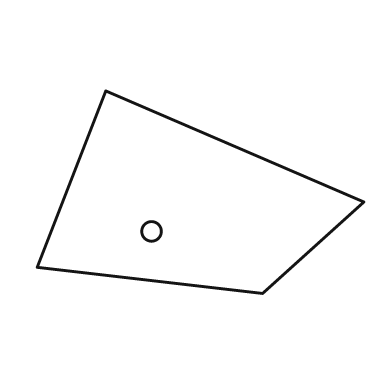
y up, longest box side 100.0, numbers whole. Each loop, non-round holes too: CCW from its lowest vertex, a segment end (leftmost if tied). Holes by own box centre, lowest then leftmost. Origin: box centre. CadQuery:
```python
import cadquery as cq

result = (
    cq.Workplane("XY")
    .moveTo(19.0, -31.0)
    .lineTo(50.0, -3.0)
    .lineTo(-29.0, 31.0)
    .lineTo(-50.0, -23.0)
    .close()
    .moveTo(-15.0, -12.0)
    .circle(3.0)
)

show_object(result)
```